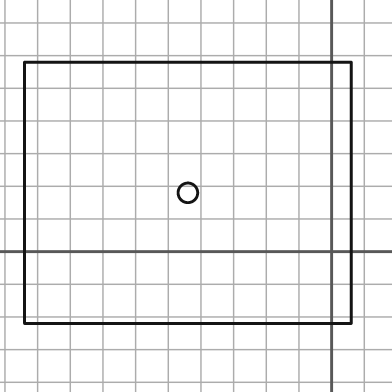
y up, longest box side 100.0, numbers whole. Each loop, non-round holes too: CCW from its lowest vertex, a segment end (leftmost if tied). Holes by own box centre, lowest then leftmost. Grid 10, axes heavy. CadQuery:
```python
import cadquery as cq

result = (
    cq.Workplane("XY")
    .moveTo(-94.0, -22.0)
    .lineTo(6.0, -22.0)
    .lineTo(6.0, 58.0)
    .lineTo(-94.0, 58.0)
    .close()
    .moveTo(-44.0, 18.0)
    .circle(3.0)
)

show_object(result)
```